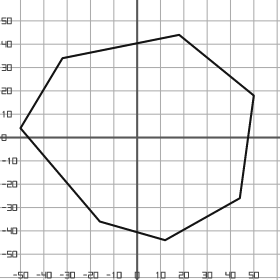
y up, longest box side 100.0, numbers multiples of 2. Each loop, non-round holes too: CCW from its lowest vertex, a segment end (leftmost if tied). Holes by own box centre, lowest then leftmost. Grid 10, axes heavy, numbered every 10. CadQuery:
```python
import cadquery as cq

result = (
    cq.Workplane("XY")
    .moveTo(12.0, -44.0)
    .lineTo(44.0, -26.0)
    .lineTo(50.0, 18.0)
    .lineTo(18.0, 44.0)
    .lineTo(-32.0, 34.0)
    .lineTo(-50.0, 4.0)
    .lineTo(-16.0, -36.0)
    .close()
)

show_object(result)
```